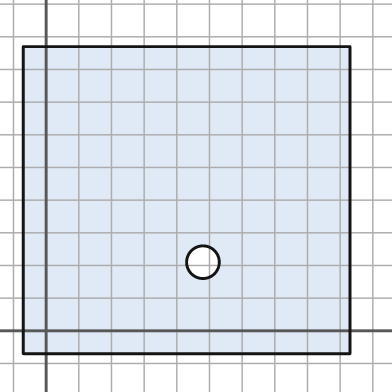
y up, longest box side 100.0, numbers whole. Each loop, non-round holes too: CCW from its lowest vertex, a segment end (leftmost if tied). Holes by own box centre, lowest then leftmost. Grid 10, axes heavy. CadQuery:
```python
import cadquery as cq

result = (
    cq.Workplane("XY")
    .moveTo(-7.0, -7.0)
    .lineTo(93.0, -7.0)
    .lineTo(93.0, 87.0)
    .lineTo(-7.0, 87.0)
    .close()
    .moveTo(48.0, 21.0)
    .circle(5.0)
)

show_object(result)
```